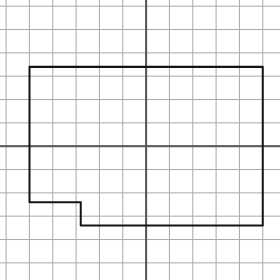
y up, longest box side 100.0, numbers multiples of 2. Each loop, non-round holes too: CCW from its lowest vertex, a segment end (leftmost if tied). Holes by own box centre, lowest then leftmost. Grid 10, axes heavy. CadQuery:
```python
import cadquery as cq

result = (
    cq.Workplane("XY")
    .moveTo(-28.0, -34.0)
    .lineTo(50.0, -34.0)
    .lineTo(50.0, 34.0)
    .lineTo(-50.0, 34.0)
    .lineTo(-50.0, -24.0)
    .lineTo(-28.0, -24.0)
    .close()
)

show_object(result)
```